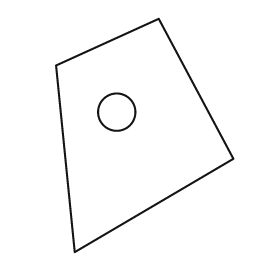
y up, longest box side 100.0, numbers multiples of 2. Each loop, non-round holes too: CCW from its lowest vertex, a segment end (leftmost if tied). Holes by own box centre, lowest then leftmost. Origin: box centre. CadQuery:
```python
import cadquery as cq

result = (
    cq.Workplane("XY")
    .moveTo(-30.0, -50.0)
    .lineTo(38.0, -10.0)
    .lineTo(6.0, 50.0)
    .lineTo(-38.0, 30.0)
    .close()
    .moveTo(-12.0, 10.0)
    .circle(8.0)
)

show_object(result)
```